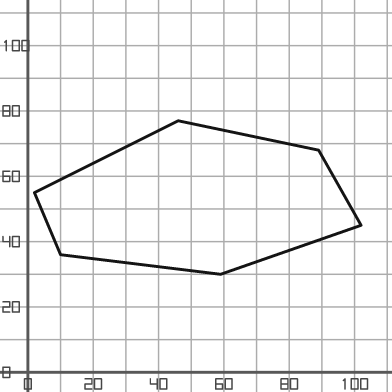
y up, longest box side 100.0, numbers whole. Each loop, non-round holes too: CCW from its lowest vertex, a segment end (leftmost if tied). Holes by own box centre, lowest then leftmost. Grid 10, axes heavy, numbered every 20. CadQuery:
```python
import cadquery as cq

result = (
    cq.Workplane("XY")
    .moveTo(59.0, 30.0)
    .lineTo(102.0, 45.0)
    .lineTo(89.0, 68.0)
    .lineTo(46.0, 77.0)
    .lineTo(2.0, 55.0)
    .lineTo(10.0, 36.0)
    .close()
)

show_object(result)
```